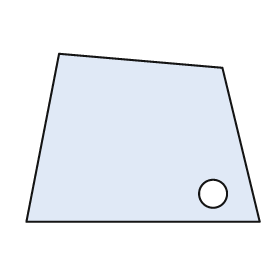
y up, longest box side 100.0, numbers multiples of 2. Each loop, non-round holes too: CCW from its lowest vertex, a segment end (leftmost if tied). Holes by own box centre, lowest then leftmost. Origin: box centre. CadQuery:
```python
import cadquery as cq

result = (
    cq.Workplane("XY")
    .moveTo(-50.0, -36.0)
    .lineTo(50.0, -36.0)
    .lineTo(34.0, 30.0)
    .lineTo(-36.0, 36.0)
    .close()
    .moveTo(30.0, -24.0)
    .circle(6.0)
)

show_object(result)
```